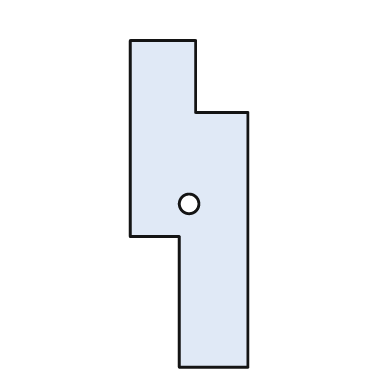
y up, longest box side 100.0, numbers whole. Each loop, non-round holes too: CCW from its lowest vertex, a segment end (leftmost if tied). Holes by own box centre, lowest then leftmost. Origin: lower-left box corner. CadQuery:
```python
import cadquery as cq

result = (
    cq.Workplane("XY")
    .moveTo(15.0, 0.0)
    .lineTo(36.0, 0.0)
    .lineTo(36.0, 78.0)
    .lineTo(20.0, 78.0)
    .lineTo(20.0, 100.0)
    .lineTo(0.0, 100.0)
    .lineTo(0.0, 40.0)
    .lineTo(15.0, 40.0)
    .close()
    .moveTo(18.0, 50.0)
    .circle(3.0)
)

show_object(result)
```